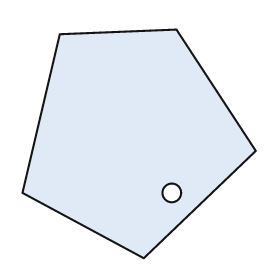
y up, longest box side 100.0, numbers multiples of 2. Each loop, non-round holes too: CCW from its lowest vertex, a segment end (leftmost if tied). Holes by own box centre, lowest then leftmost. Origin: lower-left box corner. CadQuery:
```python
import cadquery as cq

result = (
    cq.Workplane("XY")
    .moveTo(52.0, 0.0)
    .lineTo(100.0, 46.0)
    .lineTo(66.0, 98.0)
    .lineTo(16.0, 96.0)
    .lineTo(0.0, 28.0)
    .close()
    .moveTo(64.0, 28.0)
    .circle(4.0)
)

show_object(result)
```